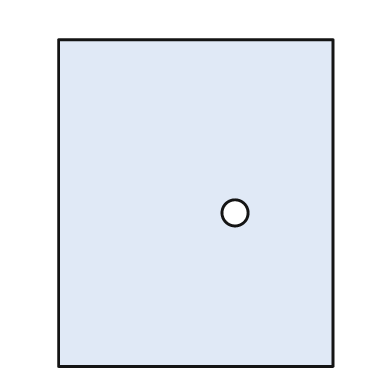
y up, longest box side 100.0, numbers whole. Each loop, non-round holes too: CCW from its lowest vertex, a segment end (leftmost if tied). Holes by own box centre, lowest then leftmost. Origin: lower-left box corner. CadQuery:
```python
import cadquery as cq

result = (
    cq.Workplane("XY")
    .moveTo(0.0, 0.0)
    .lineTo(84.0, 0.0)
    .lineTo(84.0, 100.0)
    .lineTo(0.0, 100.0)
    .close()
    .moveTo(54.0, 47.0)
    .circle(4.0)
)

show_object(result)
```